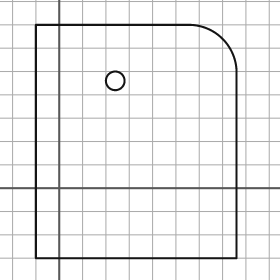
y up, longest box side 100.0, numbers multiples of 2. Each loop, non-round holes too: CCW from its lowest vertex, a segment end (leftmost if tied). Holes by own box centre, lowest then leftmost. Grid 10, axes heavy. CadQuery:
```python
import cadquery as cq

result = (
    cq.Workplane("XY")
    .moveTo(-10.0, -30.0)
    .lineTo(76.0, -30.0)
    .lineTo(76.0, 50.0)
    .threePointArc((70.0, 64.0), (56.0, 70.0))
    .lineTo(-10.0, 70.0)
    .close()
    .moveTo(24.0, 46.0)
    .circle(4.0)
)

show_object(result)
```